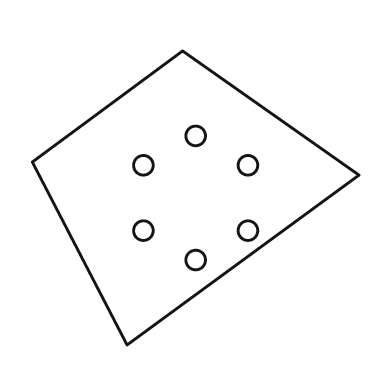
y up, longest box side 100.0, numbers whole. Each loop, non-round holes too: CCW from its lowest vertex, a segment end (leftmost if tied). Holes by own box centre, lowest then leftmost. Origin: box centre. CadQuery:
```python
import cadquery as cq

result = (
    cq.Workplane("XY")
    .moveTo(-21.0, -45.0)
    .lineTo(50.0, 7.0)
    .lineTo(-4.0, 45.0)
    .lineTo(-50.0, 11.0)
    .close()
    .moveTo(0.0, -19.0)
    .circle(3.0)
    .moveTo(-16.0, -10.0)
    .circle(3.0)
    .moveTo(16.0, -10.0)
    .circle(3.0)
    .moveTo(-16.0, 10.0)
    .circle(3.0)
    .moveTo(16.0, 10.0)
    .circle(3.0)
    .moveTo(0.0, 19.0)
    .circle(3.0)
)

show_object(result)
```